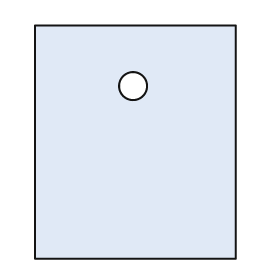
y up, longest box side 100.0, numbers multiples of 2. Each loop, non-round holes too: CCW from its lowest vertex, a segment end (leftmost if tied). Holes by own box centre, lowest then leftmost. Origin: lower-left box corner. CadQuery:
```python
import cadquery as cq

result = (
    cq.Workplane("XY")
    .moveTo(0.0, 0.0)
    .lineTo(86.0, 0.0)
    .lineTo(86.0, 100.0)
    .lineTo(0.0, 100.0)
    .close()
    .moveTo(42.0, 74.0)
    .circle(6.0)
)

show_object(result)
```